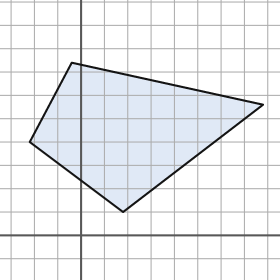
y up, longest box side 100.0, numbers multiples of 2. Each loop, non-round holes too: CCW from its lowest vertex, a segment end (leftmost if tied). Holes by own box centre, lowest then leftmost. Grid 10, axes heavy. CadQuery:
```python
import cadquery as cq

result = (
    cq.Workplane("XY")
    .moveTo(18.0, 10.0)
    .lineTo(78.0, 56.0)
    .lineTo(-4.0, 74.0)
    .lineTo(-22.0, 40.0)
    .close()
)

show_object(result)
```